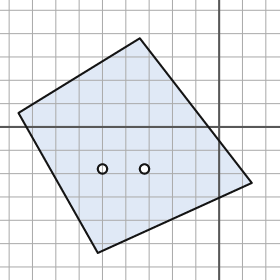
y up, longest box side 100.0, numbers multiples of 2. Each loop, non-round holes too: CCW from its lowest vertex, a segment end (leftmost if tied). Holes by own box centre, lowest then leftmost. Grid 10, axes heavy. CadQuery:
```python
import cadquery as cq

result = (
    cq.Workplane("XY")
    .moveTo(-52.0, -54.0)
    .lineTo(14.0, -24.0)
    .lineTo(-34.0, 38.0)
    .lineTo(-86.0, 6.0)
    .close()
    .moveTo(-50.0, -18.0)
    .circle(2.0)
    .moveTo(-32.0, -18.0)
    .circle(2.0)
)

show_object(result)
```